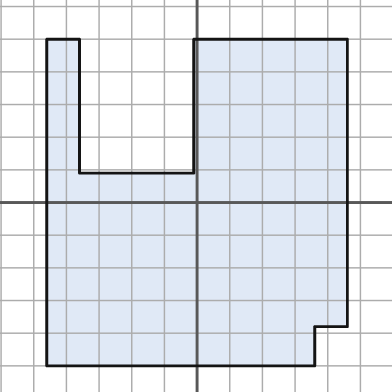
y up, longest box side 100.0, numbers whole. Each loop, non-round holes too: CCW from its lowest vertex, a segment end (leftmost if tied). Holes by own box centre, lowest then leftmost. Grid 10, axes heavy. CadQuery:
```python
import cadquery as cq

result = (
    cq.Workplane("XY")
    .moveTo(-46.0, -50.0)
    .lineTo(36.0, -50.0)
    .lineTo(36.0, -38.0)
    .lineTo(46.0, -38.0)
    .lineTo(46.0, 50.0)
    .lineTo(-1.0, 50.0)
    .lineTo(-1.0, 9.0)
    .lineTo(-36.0, 9.0)
    .lineTo(-36.0, 50.0)
    .lineTo(-46.0, 50.0)
    .close()
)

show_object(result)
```